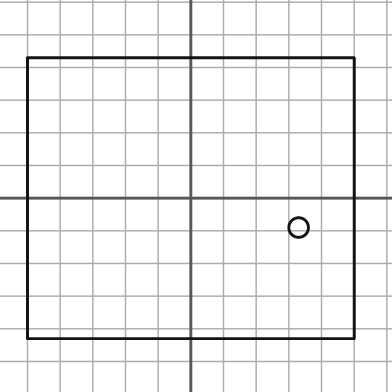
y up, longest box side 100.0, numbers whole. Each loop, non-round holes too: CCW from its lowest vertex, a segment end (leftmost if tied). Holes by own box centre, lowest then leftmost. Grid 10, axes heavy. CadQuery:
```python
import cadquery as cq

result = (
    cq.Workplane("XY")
    .moveTo(-50.0, -43.0)
    .lineTo(50.0, -43.0)
    .lineTo(50.0, 43.0)
    .lineTo(-50.0, 43.0)
    .close()
    .moveTo(33.0, -9.0)
    .circle(3.0)
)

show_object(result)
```